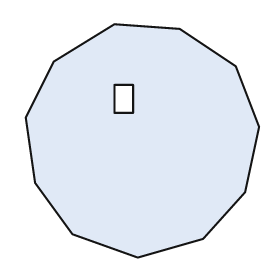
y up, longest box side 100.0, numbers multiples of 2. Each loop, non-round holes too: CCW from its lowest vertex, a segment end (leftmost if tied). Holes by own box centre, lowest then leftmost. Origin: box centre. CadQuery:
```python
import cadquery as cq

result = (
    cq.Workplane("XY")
    .moveTo(-2.0, -50.0)
    .lineTo(26.0, -42.0)
    .lineTo(44.0, -22.0)
    .lineTo(50.0, 6.0)
    .lineTo(40.0, 32.0)
    .lineTo(16.0, 48.0)
    .lineTo(-12.0, 50.0)
    .lineTo(-38.0, 34.0)
    .lineTo(-50.0, 10.0)
    .lineTo(-46.0, -18.0)
    .lineTo(-30.0, -40.0)
    .close()
    .moveTo(-12.0, 12.0)
    .lineTo(-4.0, 12.0)
    .lineTo(-4.0, 24.0)
    .lineTo(-12.0, 24.0)
    .close()
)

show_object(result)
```